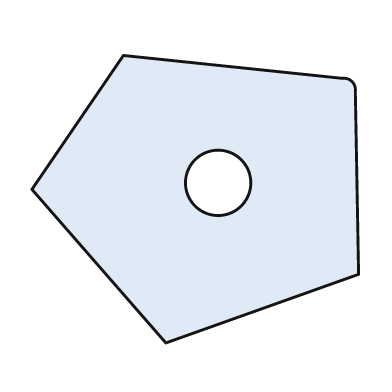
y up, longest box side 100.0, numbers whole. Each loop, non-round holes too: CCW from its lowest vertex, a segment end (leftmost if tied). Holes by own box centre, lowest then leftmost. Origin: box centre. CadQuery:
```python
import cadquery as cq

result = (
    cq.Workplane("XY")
    .moveTo(-9.0, -44.0)
    .lineTo(50.0, -23.0)
    .lineTo(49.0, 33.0)
    .threePointArc((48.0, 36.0), (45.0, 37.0))
    .lineTo(-22.0, 44.0)
    .lineTo(-50.0, 3.0)
    .close()
    .moveTo(7.0, 5.0)
    .circle(10.0)
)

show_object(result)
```